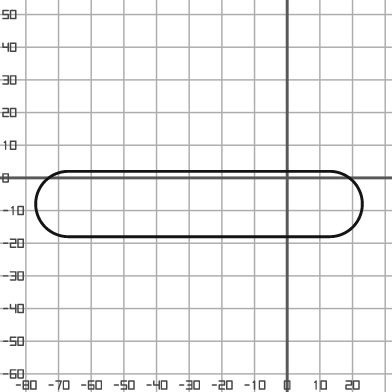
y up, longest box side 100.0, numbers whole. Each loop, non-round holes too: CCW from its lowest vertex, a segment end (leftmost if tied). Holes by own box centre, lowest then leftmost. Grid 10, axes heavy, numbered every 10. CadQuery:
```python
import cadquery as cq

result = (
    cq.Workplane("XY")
    .moveTo(-67.0, -18.0)
    .lineTo(13.0, -18.0)
    .threePointArc((23.0, -8.0), (13.0, 2.0))
    .lineTo(-67.0, 2.0)
    .threePointArc((-77.0, -8.0), (-67.0, -18.0))
    .close()
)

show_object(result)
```